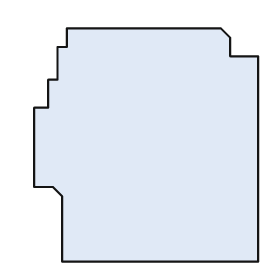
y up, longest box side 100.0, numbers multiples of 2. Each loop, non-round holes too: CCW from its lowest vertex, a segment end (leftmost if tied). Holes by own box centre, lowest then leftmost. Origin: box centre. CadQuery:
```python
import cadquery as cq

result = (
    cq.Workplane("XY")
    .moveTo(-36.0, -50.0)
    .lineTo(48.0, -50.0)
    .lineTo(48.0, 38.0)
    .lineTo(36.0, 38.0)
    .lineTo(36.0, 46.0)
    .lineTo(32.0, 50.0)
    .lineTo(-34.0, 50.0)
    .lineTo(-34.0, 42.0)
    .lineTo(-38.0, 42.0)
    .lineTo(-38.0, 28.0)
    .lineTo(-42.0, 28.0)
    .lineTo(-42.0, 16.0)
    .lineTo(-48.0, 16.0)
    .lineTo(-48.0, -18.0)
    .lineTo(-40.0, -18.0)
    .lineTo(-36.0, -22.0)
    .close()
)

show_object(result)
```